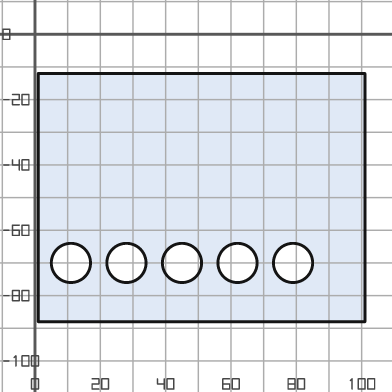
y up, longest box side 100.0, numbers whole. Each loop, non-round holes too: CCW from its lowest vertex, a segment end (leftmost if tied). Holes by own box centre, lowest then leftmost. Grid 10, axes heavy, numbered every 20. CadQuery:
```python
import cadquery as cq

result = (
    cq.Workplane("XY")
    .moveTo(1.0, -88.0)
    .lineTo(101.0, -88.0)
    .lineTo(101.0, -12.0)
    .lineTo(1.0, -12.0)
    .close()
    .moveTo(11.0, -70.0)
    .circle(6.0)
    .moveTo(28.0, -70.0)
    .circle(6.0)
    .moveTo(45.0, -70.0)
    .circle(6.0)
    .moveTo(62.0, -70.0)
    .circle(6.0)
    .moveTo(79.0, -70.0)
    .circle(6.0)
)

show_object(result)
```